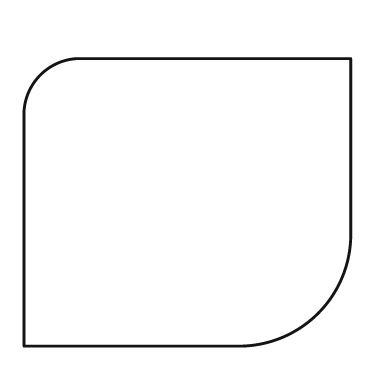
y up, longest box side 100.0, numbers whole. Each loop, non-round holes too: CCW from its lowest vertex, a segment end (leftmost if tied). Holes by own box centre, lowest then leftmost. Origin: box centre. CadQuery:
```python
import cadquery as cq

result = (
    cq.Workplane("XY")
    .moveTo(-50.0, -44.0)
    .lineTo(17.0, -44.0)
    .threePointArc((40.0, -34.0), (50.0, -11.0))
    .lineTo(50.0, 44.0)
    .lineTo(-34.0, 44.0)
    .threePointArc((-45.0, 39.0), (-50.0, 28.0))
    .close()
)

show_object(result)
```